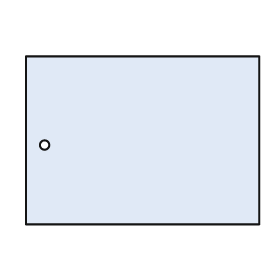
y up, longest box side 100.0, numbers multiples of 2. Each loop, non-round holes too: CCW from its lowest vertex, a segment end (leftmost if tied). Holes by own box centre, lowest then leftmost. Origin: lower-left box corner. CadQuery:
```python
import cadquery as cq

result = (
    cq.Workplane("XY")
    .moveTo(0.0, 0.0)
    .lineTo(100.0, 0.0)
    .lineTo(100.0, 72.0)
    .lineTo(0.0, 72.0)
    .close()
    .moveTo(8.0, 34.0)
    .circle(2.0)
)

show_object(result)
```